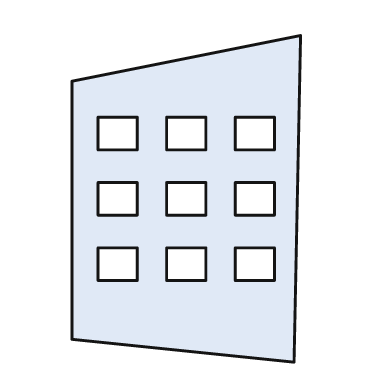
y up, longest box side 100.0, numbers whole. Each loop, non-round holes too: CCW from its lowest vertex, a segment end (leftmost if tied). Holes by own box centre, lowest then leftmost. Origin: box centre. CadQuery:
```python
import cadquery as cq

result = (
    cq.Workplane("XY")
    .moveTo(33.0, -50.0)
    .lineTo(35.0, 50.0)
    .lineTo(-35.0, 36.0)
    .lineTo(-35.0, -43.0)
    .close()
    .moveTo(-27.0, -25.0)
    .lineTo(-15.0, -25.0)
    .lineTo(-15.0, -15.0)
    .lineTo(-27.0, -15.0)
    .close()
    .moveTo(-6.0, -25.0)
    .lineTo(6.0, -25.0)
    .lineTo(6.0, -15.0)
    .lineTo(-6.0, -15.0)
    .close()
    .moveTo(15.0, -25.0)
    .lineTo(27.0, -25.0)
    .lineTo(27.0, -15.0)
    .lineTo(15.0, -15.0)
    .close()
    .moveTo(-27.0, -5.0)
    .lineTo(-15.0, -5.0)
    .lineTo(-15.0, 5.0)
    .lineTo(-27.0, 5.0)
    .close()
    .moveTo(-6.0, -5.0)
    .lineTo(6.0, -5.0)
    .lineTo(6.0, 5.0)
    .lineTo(-6.0, 5.0)
    .close()
    .moveTo(15.0, -5.0)
    .lineTo(27.0, -5.0)
    .lineTo(27.0, 5.0)
    .lineTo(15.0, 5.0)
    .close()
    .moveTo(-27.0, 15.0)
    .lineTo(-15.0, 15.0)
    .lineTo(-15.0, 25.0)
    .lineTo(-27.0, 25.0)
    .close()
    .moveTo(-6.0, 15.0)
    .lineTo(6.0, 15.0)
    .lineTo(6.0, 25.0)
    .lineTo(-6.0, 25.0)
    .close()
    .moveTo(15.0, 15.0)
    .lineTo(27.0, 15.0)
    .lineTo(27.0, 25.0)
    .lineTo(15.0, 25.0)
    .close()
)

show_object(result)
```